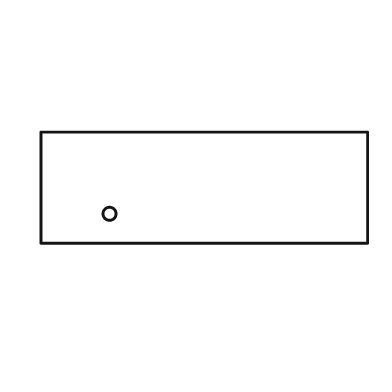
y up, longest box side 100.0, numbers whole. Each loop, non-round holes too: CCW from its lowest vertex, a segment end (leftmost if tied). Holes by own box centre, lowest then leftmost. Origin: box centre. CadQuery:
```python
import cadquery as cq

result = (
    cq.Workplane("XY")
    .moveTo(-50.0, -17.0)
    .lineTo(50.0, -17.0)
    .lineTo(50.0, 17.0)
    .lineTo(-50.0, 17.0)
    .close()
    .moveTo(-29.0, -8.0)
    .circle(2.0)
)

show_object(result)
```